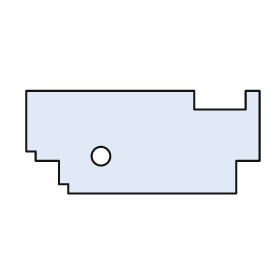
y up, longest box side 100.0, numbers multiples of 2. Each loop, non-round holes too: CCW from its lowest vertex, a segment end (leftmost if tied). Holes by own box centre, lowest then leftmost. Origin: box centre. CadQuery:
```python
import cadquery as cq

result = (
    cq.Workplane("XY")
    .moveTo(-32.0, -22.0)
    .lineTo(40.0, -22.0)
    .lineTo(40.0, -8.0)
    .lineTo(50.0, -8.0)
    .lineTo(50.0, 22.0)
    .lineTo(44.0, 22.0)
    .lineTo(44.0, 14.0)
    .lineTo(22.0, 14.0)
    .lineTo(22.0, 22.0)
    .lineTo(-50.0, 22.0)
    .lineTo(-50.0, -4.0)
    .lineTo(-46.0, -4.0)
    .lineTo(-46.0, -8.0)
    .lineTo(-36.0, -8.0)
    .lineTo(-36.0, -18.0)
    .lineTo(-32.0, -18.0)
    .close()
    .moveTo(-18.0, -6.0)
    .circle(4.0)
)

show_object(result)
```